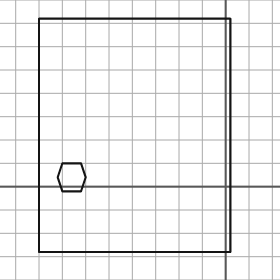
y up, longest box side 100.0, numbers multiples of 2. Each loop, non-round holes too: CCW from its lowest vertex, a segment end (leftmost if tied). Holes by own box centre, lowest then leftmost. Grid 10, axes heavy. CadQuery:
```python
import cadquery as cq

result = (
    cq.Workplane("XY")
    .moveTo(-80.0, -28.0)
    .lineTo(2.0, -28.0)
    .lineTo(2.0, 72.0)
    .lineTo(-80.0, 72.0)
    .close()
    .moveTo(-70.0, -2.0)
    .lineTo(-62.0, -2.0)
    .lineTo(-60.0, 4.0)
    .lineTo(-62.0, 10.0)
    .lineTo(-70.0, 10.0)
    .lineTo(-72.0, 4.0)
    .close()
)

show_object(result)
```